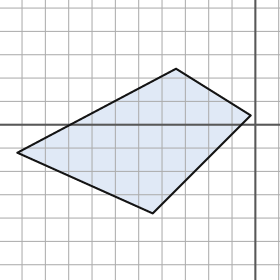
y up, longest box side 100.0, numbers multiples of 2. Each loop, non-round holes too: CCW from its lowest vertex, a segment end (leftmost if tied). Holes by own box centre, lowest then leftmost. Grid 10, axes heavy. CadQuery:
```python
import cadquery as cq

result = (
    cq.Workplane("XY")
    .moveTo(-44.0, -38.0)
    .lineTo(-2.0, 4.0)
    .lineTo(-34.0, 24.0)
    .lineTo(-102.0, -12.0)
    .close()
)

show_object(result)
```